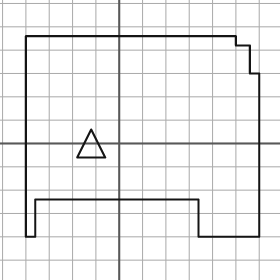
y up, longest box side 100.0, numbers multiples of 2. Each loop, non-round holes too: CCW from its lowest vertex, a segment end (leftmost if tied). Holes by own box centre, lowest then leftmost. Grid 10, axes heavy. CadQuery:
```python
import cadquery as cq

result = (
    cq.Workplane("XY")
    .moveTo(-40.0, -40.0)
    .lineTo(-36.0, -40.0)
    .lineTo(-36.0, -24.0)
    .lineTo(34.0, -24.0)
    .lineTo(34.0, -40.0)
    .lineTo(60.0, -40.0)
    .lineTo(60.0, 30.0)
    .lineTo(56.0, 30.0)
    .lineTo(56.0, 42.0)
    .lineTo(50.0, 42.0)
    .lineTo(50.0, 46.0)
    .lineTo(-40.0, 46.0)
    .close()
    .moveTo(-18.0, -6.0)
    .lineTo(-6.0, -6.0)
    .lineTo(-12.0, 6.0)
    .close()
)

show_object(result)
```